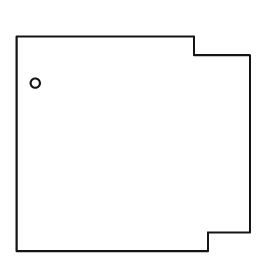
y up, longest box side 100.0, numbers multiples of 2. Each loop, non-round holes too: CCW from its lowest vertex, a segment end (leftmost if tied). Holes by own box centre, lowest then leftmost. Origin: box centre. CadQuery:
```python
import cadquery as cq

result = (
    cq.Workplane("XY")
    .moveTo(-50.0, -46.0)
    .lineTo(32.0, -46.0)
    .lineTo(32.0, -38.0)
    .lineTo(50.0, -38.0)
    .lineTo(50.0, 38.0)
    .lineTo(26.0, 38.0)
    .lineTo(26.0, 46.0)
    .lineTo(-50.0, 46.0)
    .close()
    .moveTo(-42.0, 26.0)
    .circle(2.0)
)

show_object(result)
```